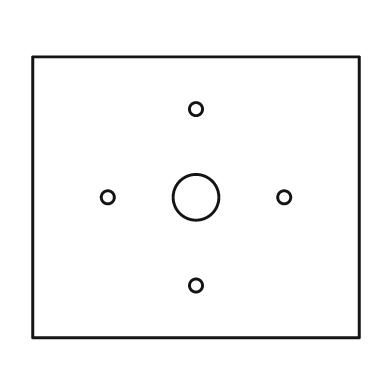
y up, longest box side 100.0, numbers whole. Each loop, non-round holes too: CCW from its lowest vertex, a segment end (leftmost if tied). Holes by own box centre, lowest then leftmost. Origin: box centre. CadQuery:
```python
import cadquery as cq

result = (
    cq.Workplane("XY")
    .moveTo(-50.0, -43.0)
    .lineTo(50.0, -43.0)
    .lineTo(50.0, 43.0)
    .lineTo(-50.0, 43.0)
    .close()
    .moveTo(0.0, -27.0)
    .circle(2.0)
    .moveTo(-27.0, 0.0)
    .circle(2.0)
    .moveTo(0.0, 0.0)
    .circle(7.0)
    .moveTo(27.0, 0.0)
    .circle(2.0)
    .moveTo(0.0, 27.0)
    .circle(2.0)
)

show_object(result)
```